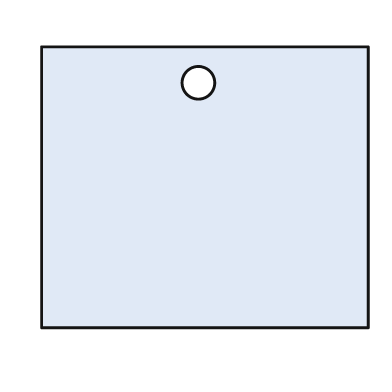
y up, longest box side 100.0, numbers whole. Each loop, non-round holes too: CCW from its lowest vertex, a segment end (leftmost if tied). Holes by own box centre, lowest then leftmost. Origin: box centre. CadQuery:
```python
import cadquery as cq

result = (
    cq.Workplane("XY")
    .moveTo(-50.0, -43.0)
    .lineTo(50.0, -43.0)
    .lineTo(50.0, 43.0)
    .lineTo(-50.0, 43.0)
    .close()
    .moveTo(-2.0, 32.0)
    .circle(5.0)
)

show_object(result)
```